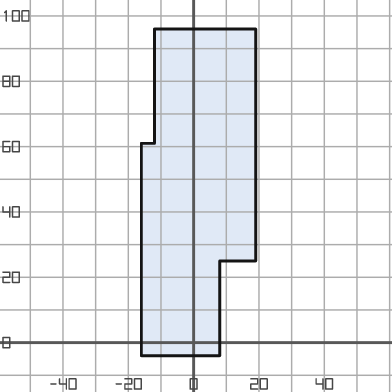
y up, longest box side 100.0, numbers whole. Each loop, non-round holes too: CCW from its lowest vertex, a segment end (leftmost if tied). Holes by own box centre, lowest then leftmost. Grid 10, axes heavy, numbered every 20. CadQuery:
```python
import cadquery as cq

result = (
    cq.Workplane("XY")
    .moveTo(-16.0, -4.0)
    .lineTo(8.0, -4.0)
    .lineTo(8.0, 25.0)
    .lineTo(19.0, 25.0)
    .lineTo(19.0, 96.0)
    .lineTo(-12.0, 96.0)
    .lineTo(-12.0, 61.0)
    .lineTo(-16.0, 61.0)
    .close()
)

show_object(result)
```